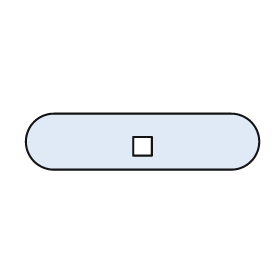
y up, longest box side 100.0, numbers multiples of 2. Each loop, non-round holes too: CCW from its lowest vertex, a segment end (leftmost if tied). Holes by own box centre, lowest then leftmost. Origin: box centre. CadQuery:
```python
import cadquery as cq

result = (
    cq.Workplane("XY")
    .moveTo(-38.0, -12.0)
    .lineTo(38.0, -12.0)
    .threePointArc((50.0, 0.0), (38.0, 12.0))
    .lineTo(-38.0, 12.0)
    .threePointArc((-50.0, 0.0), (-38.0, -12.0))
    .close()
    .moveTo(-4.0, -6.0)
    .lineTo(4.0, -6.0)
    .lineTo(4.0, 2.0)
    .lineTo(-4.0, 2.0)
    .close()
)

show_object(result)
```